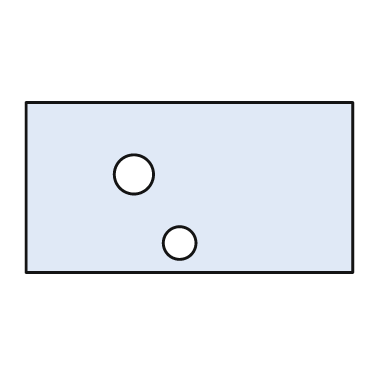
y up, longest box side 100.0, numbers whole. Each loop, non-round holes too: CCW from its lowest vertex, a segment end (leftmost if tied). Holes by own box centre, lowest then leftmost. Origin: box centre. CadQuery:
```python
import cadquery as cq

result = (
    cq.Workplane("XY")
    .moveTo(-50.0, -26.0)
    .lineTo(50.0, -26.0)
    .lineTo(50.0, 26.0)
    .lineTo(-50.0, 26.0)
    .close()
    .moveTo(-3.0, -17.0)
    .circle(5.0)
    .moveTo(-17.0, 4.0)
    .circle(6.0)
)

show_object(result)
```